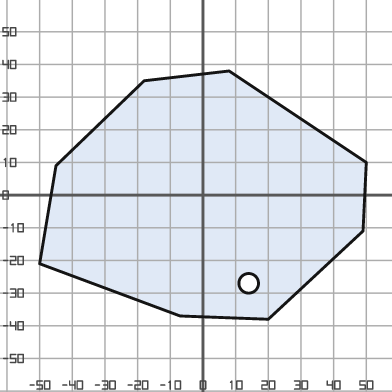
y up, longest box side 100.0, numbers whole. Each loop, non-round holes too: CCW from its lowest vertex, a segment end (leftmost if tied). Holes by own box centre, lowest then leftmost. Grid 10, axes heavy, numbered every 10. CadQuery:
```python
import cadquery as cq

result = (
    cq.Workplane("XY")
    .moveTo(20.0, -38.0)
    .lineTo(49.0, -11.0)
    .lineTo(50.0, 10.0)
    .lineTo(8.0, 38.0)
    .lineTo(-18.0, 35.0)
    .lineTo(-45.0, 9.0)
    .lineTo(-50.0, -21.0)
    .lineTo(-7.0, -37.0)
    .close()
    .moveTo(14.0, -27.0)
    .circle(3.0)
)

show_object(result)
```